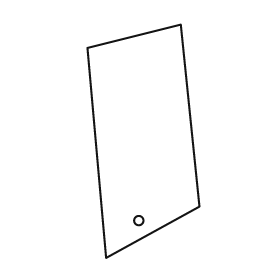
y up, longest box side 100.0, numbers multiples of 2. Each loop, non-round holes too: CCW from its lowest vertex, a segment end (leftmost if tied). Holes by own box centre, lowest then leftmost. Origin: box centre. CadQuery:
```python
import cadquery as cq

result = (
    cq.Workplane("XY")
    .moveTo(-16.0, -50.0)
    .lineTo(24.0, -28.0)
    .lineTo(16.0, 50.0)
    .lineTo(-24.0, 40.0)
    .close()
    .moveTo(-2.0, -34.0)
    .circle(2.0)
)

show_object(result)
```